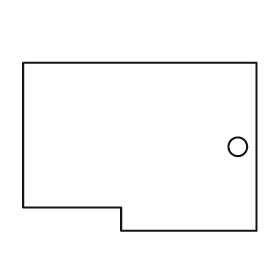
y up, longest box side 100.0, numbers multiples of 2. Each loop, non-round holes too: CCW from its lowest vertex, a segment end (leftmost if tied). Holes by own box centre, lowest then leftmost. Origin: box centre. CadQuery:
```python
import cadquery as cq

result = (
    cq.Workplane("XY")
    .moveTo(-8.0, -36.0)
    .lineTo(50.0, -36.0)
    .lineTo(50.0, 36.0)
    .lineTo(-50.0, 36.0)
    .lineTo(-50.0, -26.0)
    .lineTo(-8.0, -26.0)
    .close()
    .moveTo(42.0, 0.0)
    .circle(4.0)
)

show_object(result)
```